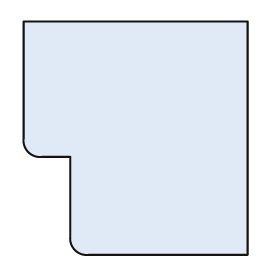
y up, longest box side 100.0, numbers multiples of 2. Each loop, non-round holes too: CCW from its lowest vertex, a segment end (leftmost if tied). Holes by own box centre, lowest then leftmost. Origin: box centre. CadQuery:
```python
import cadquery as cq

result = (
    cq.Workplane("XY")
    .moveTo(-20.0, -50.0)
    .lineTo(48.0, -50.0)
    .lineTo(48.0, 50.0)
    .lineTo(-48.0, 50.0)
    .lineTo(-48.0, 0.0)
    .threePointArc((-46.0, -6.0), (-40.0, -8.0))
    .lineTo(-28.0, -8.0)
    .lineTo(-28.0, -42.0)
    .threePointArc((-26.0, -48.0), (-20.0, -50.0))
    .close()
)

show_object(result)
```